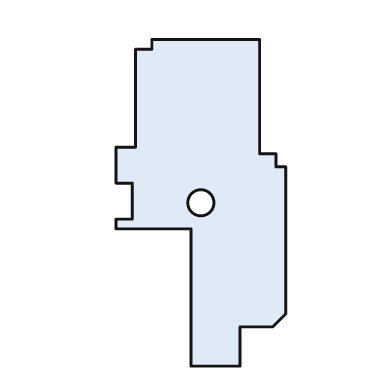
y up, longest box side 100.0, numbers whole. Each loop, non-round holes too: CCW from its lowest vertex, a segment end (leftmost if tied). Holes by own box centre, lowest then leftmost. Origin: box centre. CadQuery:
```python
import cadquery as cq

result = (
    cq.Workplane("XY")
    .moveTo(-3.0, -50.0)
    .lineTo(12.0, -50.0)
    .lineTo(12.0, -38.0)
    .lineTo(22.0, -38.0)
    .lineTo(26.0, -34.0)
    .lineTo(26.0, 11.0)
    .lineTo(23.0, 11.0)
    .lineTo(23.0, 15.0)
    .lineTo(18.0, 15.0)
    .lineTo(18.0, 50.0)
    .lineTo(-15.0, 50.0)
    .lineTo(-15.0, 47.0)
    .lineTo(-20.0, 47.0)
    .lineTo(-20.0, 17.0)
    .lineTo(-26.0, 17.0)
    .lineTo(-26.0, 6.0)
    .lineTo(-21.0, 6.0)
    .lineTo(-21.0, -5.0)
    .lineTo(-26.0, -5.0)
    .lineTo(-26.0, -8.0)
    .lineTo(-3.0, -8.0)
    .close()
    .moveTo(0.0, 0.0)
    .circle(4.0)
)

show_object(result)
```